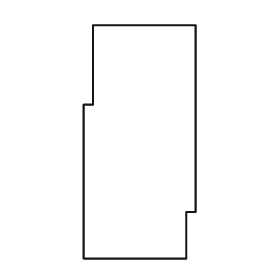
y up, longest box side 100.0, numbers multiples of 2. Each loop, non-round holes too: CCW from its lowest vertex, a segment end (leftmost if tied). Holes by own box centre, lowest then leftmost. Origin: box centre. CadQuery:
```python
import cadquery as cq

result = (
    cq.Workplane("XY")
    .moveTo(-24.0, -50.0)
    .lineTo(20.0, -50.0)
    .lineTo(20.0, -30.0)
    .lineTo(24.0, -30.0)
    .lineTo(24.0, 50.0)
    .lineTo(-20.0, 50.0)
    .lineTo(-20.0, 16.0)
    .lineTo(-24.0, 16.0)
    .close()
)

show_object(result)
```